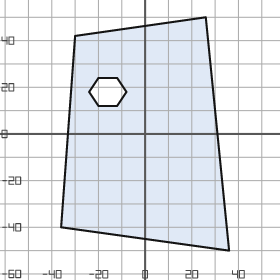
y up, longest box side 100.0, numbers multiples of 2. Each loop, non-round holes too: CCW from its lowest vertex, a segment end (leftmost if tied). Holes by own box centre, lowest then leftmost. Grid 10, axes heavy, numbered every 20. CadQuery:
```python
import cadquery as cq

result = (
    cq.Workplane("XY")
    .moveTo(36.0, -50.0)
    .lineTo(26.0, 50.0)
    .lineTo(-30.0, 42.0)
    .lineTo(-36.0, -40.0)
    .close()
    .moveTo(-20.0, 12.0)
    .lineTo(-12.0, 12.0)
    .lineTo(-8.0, 18.0)
    .lineTo(-12.0, 24.0)
    .lineTo(-20.0, 24.0)
    .lineTo(-24.0, 18.0)
    .close()
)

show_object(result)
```